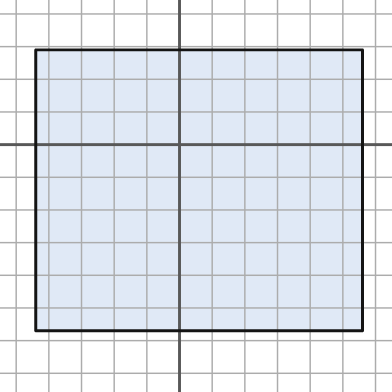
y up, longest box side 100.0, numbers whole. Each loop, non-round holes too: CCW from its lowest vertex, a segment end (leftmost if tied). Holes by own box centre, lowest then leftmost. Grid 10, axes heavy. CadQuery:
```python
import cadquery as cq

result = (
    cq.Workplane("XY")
    .moveTo(-44.0, -57.0)
    .lineTo(56.0, -57.0)
    .lineTo(56.0, 29.0)
    .lineTo(-44.0, 29.0)
    .close()
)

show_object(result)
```